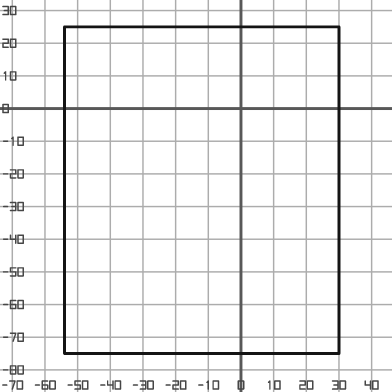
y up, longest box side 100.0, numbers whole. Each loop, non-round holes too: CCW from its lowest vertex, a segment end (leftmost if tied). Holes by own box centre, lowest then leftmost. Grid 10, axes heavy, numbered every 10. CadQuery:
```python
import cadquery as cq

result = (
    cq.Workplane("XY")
    .moveTo(-54.0, -75.0)
    .lineTo(30.0, -75.0)
    .lineTo(30.0, 25.0)
    .lineTo(-54.0, 25.0)
    .close()
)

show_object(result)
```